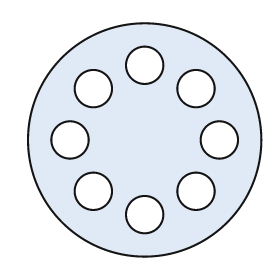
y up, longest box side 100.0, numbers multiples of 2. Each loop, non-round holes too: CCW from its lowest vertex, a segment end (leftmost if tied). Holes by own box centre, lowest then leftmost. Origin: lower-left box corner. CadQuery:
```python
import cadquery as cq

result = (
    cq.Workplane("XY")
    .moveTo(50.0, 50.0)
    .circle(50.0)
    .moveTo(50.0, 18.0)
    .circle(8.0)
    .moveTo(28.0, 28.0)
    .circle(8.0)
    .moveTo(72.0, 28.0)
    .circle(8.0)
    .moveTo(18.0, 50.0)
    .circle(8.0)
    .moveTo(82.0, 50.0)
    .circle(8.0)
    .moveTo(28.0, 72.0)
    .circle(8.0)
    .moveTo(72.0, 72.0)
    .circle(8.0)
    .moveTo(50.0, 82.0)
    .circle(8.0)
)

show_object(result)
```